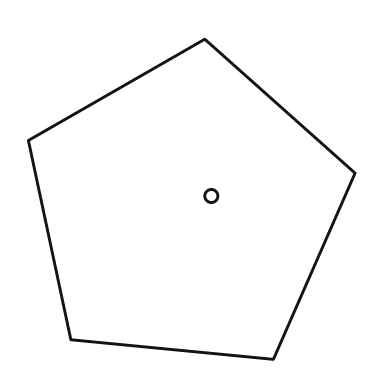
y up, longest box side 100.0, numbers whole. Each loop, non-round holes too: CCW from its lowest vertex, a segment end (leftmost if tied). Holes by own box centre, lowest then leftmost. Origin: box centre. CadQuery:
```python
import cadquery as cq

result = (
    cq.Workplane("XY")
    .moveTo(25.0, -49.0)
    .lineTo(50.0, 8.0)
    .lineTo(4.0, 49.0)
    .lineTo(-50.0, 18.0)
    .lineTo(-37.0, -43.0)
    .close()
    .moveTo(6.0, 1.0)
    .circle(2.0)
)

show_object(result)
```